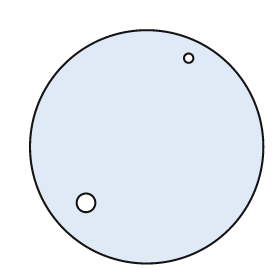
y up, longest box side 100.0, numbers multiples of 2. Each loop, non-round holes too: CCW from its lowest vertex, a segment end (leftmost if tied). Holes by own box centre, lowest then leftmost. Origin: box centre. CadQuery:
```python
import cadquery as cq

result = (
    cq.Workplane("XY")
    .moveTo(0.0, 0.0)
    .circle(50.0)
    .moveTo(-26.0, -24.0)
    .circle(4.0)
    .moveTo(18.0, 38.0)
    .circle(2.0)
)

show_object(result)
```